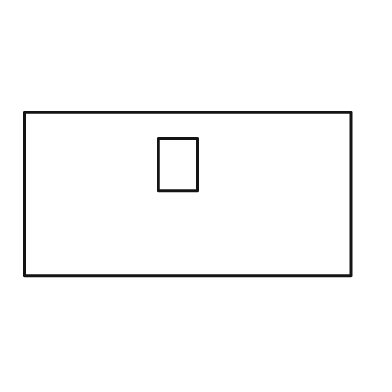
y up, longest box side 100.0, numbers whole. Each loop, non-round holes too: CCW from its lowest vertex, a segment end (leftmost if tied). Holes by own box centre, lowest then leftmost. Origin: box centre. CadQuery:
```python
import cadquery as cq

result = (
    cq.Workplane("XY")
    .moveTo(-50.0, -25.0)
    .lineTo(50.0, -25.0)
    .lineTo(50.0, 25.0)
    .lineTo(-50.0, 25.0)
    .close()
    .moveTo(-9.0, 1.0)
    .lineTo(3.0, 1.0)
    .lineTo(3.0, 17.0)
    .lineTo(-9.0, 17.0)
    .close()
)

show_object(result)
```